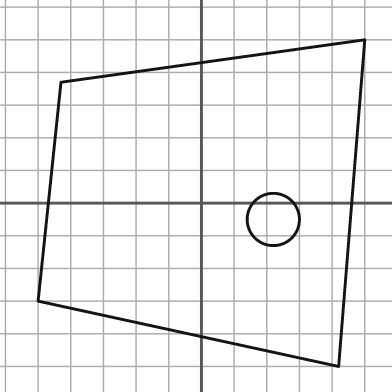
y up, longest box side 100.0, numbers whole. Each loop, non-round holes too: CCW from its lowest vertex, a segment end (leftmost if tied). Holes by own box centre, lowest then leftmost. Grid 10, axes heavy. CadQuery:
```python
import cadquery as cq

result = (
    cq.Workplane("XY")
    .moveTo(42.0, -50.0)
    .lineTo(50.0, 50.0)
    .lineTo(-43.0, 37.0)
    .lineTo(-50.0, -30.0)
    .close()
    .moveTo(22.0, -5.0)
    .circle(8.0)
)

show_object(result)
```